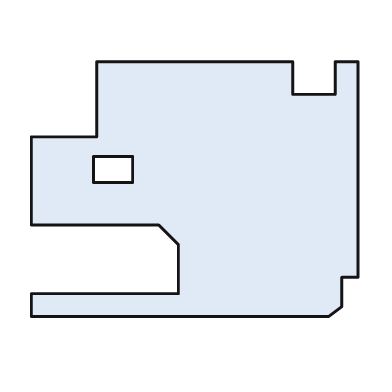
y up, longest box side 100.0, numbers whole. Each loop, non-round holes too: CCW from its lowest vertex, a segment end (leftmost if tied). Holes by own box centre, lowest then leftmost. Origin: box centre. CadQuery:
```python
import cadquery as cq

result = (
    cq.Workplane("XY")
    .moveTo(-50.0, -39.0)
    .lineTo(41.0, -39.0)
    .lineTo(45.0, -36.0)
    .lineTo(45.0, -27.0)
    .lineTo(50.0, -27.0)
    .lineTo(50.0, 39.0)
    .lineTo(43.0, 39.0)
    .lineTo(43.0, 29.0)
    .lineTo(30.0, 29.0)
    .lineTo(30.0, 39.0)
    .lineTo(-30.0, 39.0)
    .lineTo(-30.0, 16.0)
    .lineTo(-50.0, 16.0)
    .lineTo(-50.0, -11.0)
    .lineTo(-11.0, -11.0)
    .lineTo(-5.0, -17.0)
    .lineTo(-5.0, -32.0)
    .lineTo(-50.0, -32.0)
    .close()
    .moveTo(-31.0, 2.0)
    .lineTo(-19.0, 2.0)
    .lineTo(-19.0, 10.0)
    .lineTo(-31.0, 10.0)
    .close()
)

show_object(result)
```